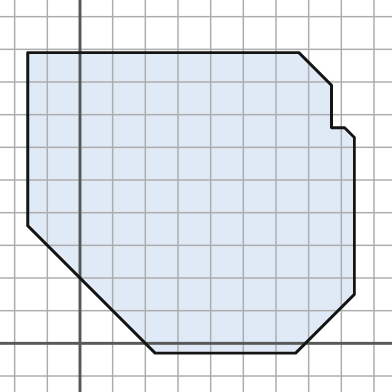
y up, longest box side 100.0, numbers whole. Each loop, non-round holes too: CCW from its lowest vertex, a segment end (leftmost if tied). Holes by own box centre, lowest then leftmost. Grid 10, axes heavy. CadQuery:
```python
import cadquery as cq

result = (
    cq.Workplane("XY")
    .moveTo(23.0, -3.0)
    .lineTo(66.0, -3.0)
    .lineTo(84.0, 15.0)
    .lineTo(84.0, 63.0)
    .lineTo(81.0, 66.0)
    .lineTo(77.0, 66.0)
    .lineTo(77.0, 79.0)
    .lineTo(67.0, 89.0)
    .lineTo(-16.0, 89.0)
    .lineTo(-16.0, 36.0)
    .close()
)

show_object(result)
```